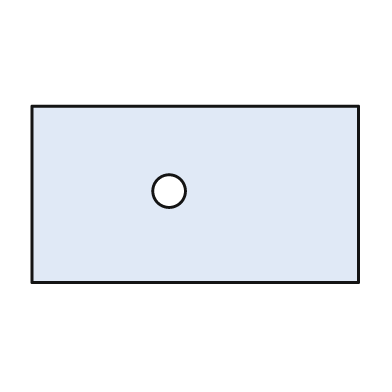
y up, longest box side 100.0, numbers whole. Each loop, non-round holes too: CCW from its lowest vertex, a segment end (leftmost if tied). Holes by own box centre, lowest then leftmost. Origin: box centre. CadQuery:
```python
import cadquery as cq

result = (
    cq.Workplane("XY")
    .moveTo(-50.0, -27.0)
    .lineTo(50.0, -27.0)
    .lineTo(50.0, 27.0)
    .lineTo(-50.0, 27.0)
    .close()
    .moveTo(-8.0, 1.0)
    .circle(5.0)
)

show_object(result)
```